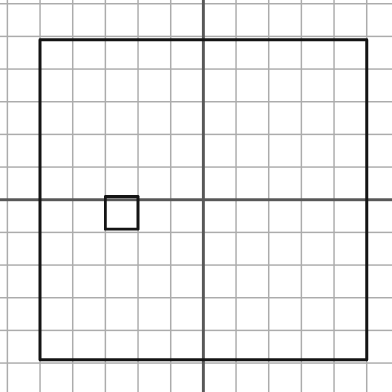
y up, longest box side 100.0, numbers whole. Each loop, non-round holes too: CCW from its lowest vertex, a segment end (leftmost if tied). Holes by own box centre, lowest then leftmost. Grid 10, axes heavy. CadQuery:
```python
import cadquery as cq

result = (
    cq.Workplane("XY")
    .moveTo(-50.0, -49.0)
    .lineTo(50.0, -49.0)
    .lineTo(50.0, 49.0)
    .lineTo(-50.0, 49.0)
    .close()
    .moveTo(-30.0, -9.0)
    .lineTo(-20.0, -9.0)
    .lineTo(-20.0, 1.0)
    .lineTo(-30.0, 1.0)
    .close()
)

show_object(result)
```